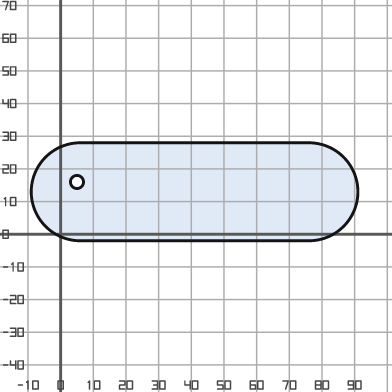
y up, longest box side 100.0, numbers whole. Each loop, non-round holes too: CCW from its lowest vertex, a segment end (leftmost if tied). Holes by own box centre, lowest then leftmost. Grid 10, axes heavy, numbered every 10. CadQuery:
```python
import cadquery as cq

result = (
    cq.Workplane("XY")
    .moveTo(6.0, -2.0)
    .lineTo(76.0, -2.0)
    .threePointArc((91.0, 13.0), (76.0, 28.0))
    .lineTo(6.0, 28.0)
    .threePointArc((-9.0, 13.0), (6.0, -2.0))
    .close()
    .moveTo(5.0, 16.0)
    .circle(2.0)
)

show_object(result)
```